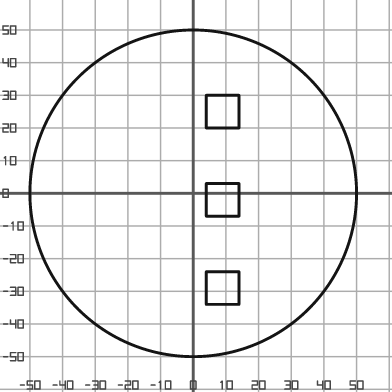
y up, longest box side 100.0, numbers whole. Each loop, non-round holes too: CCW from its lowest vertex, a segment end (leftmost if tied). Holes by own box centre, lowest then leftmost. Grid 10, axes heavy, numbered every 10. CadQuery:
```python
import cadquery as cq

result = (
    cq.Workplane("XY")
    .moveTo(0.0, 0.0)
    .circle(50.0)
    .moveTo(4.0, -34.0)
    .lineTo(14.0, -34.0)
    .lineTo(14.0, -24.0)
    .lineTo(4.0, -24.0)
    .close()
    .moveTo(4.0, -7.0)
    .lineTo(14.0, -7.0)
    .lineTo(14.0, 3.0)
    .lineTo(4.0, 3.0)
    .close()
    .moveTo(4.0, 20.0)
    .lineTo(14.0, 20.0)
    .lineTo(14.0, 30.0)
    .lineTo(4.0, 30.0)
    .close()
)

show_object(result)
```